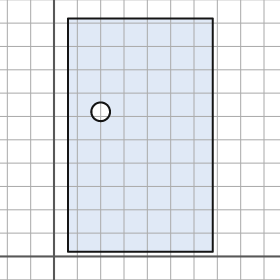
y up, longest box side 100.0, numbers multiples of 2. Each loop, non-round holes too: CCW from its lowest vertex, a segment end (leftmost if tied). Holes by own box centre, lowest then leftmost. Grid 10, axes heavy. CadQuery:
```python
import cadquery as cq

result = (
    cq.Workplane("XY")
    .moveTo(6.0, 2.0)
    .lineTo(68.0, 2.0)
    .lineTo(68.0, 102.0)
    .lineTo(6.0, 102.0)
    .close()
    .moveTo(20.0, 62.0)
    .circle(4.0)
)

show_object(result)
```